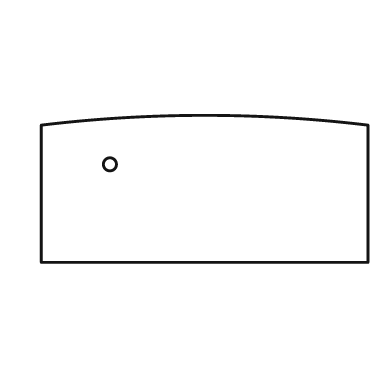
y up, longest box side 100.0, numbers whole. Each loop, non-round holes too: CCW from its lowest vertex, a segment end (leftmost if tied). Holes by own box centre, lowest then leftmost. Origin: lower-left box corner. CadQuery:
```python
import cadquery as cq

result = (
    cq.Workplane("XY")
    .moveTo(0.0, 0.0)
    .lineTo(100.0, 0.0)
    .lineTo(100.0, 42.0)
    .threePointArc((50.0, 45.0), (0.0, 42.0))
    .close()
    .moveTo(21.0, 30.0)
    .circle(2.0)
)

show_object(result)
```